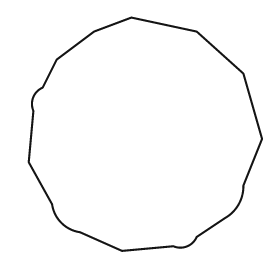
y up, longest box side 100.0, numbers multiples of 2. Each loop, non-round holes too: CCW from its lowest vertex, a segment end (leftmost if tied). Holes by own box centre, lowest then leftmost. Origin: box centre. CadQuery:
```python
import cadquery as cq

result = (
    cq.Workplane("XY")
    .moveTo(-10.0, -50.0)
    .lineTo(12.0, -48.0)
    .threePointArc((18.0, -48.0), (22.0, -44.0))
    .lineTo(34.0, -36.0)
    .threePointArc((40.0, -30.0), (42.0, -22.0))
    .lineTo(50.0, -2.0)
    .lineTo(42.0, 26.0)
    .lineTo(22.0, 44.0)
    .lineTo(-6.0, 50.0)
    .lineTo(-22.0, 44.0)
    .lineTo(-38.0, 32.0)
    .lineTo(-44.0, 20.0)
    .threePointArc((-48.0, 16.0), (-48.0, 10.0))
    .lineTo(-50.0, -12.0)
    .lineTo(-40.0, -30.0)
    .threePointArc((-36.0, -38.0), (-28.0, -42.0))
    .close()
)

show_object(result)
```